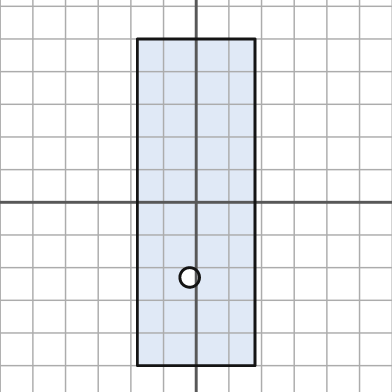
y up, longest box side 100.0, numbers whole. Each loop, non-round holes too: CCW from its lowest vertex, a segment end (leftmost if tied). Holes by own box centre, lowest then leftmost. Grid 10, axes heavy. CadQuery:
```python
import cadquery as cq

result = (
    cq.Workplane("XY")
    .moveTo(-18.0, -50.0)
    .lineTo(18.0, -50.0)
    .lineTo(18.0, 50.0)
    .lineTo(-18.0, 50.0)
    .close()
    .moveTo(-2.0, -23.0)
    .circle(3.0)
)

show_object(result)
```